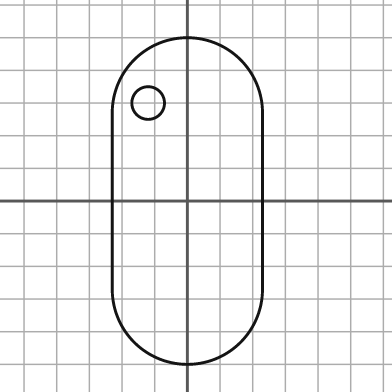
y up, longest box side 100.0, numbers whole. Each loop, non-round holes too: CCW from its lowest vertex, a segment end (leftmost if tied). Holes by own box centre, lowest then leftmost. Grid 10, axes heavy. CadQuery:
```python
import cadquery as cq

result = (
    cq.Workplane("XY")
    .moveTo(-23.0, -27.0)
    .threePointArc((0.0, -50.0), (23.0, -27.0))
    .lineTo(23.0, 27.0)
    .threePointArc((0.0, 50.0), (-23.0, 27.0))
    .close()
    .moveTo(-12.0, 30.0)
    .circle(5.0)
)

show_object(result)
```